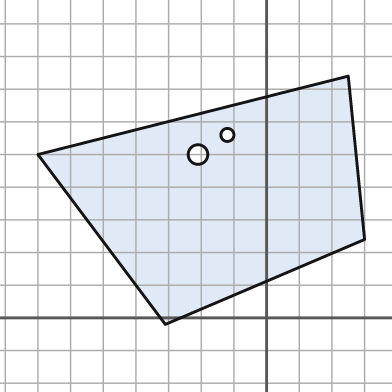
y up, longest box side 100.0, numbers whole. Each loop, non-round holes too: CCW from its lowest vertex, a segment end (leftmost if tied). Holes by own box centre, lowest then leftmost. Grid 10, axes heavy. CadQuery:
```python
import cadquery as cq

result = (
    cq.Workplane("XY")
    .moveTo(-31.0, -2.0)
    .lineTo(30.0, 24.0)
    .lineTo(25.0, 74.0)
    .lineTo(-70.0, 50.0)
    .close()
    .moveTo(-21.0, 50.0)
    .circle(3.0)
    .moveTo(-12.0, 56.0)
    .circle(2.0)
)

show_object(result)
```